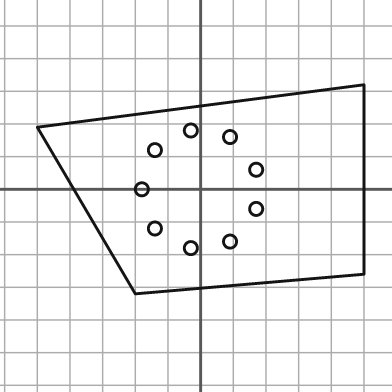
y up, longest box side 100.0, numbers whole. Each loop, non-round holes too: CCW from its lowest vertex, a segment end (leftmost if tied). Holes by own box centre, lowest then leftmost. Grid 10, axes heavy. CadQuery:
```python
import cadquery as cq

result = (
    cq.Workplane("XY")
    .moveTo(-20.0, -32.0)
    .lineTo(50.0, -26.0)
    .lineTo(50.0, 32.0)
    .lineTo(-50.0, 19.0)
    .close()
    .moveTo(-3.0, -18.0)
    .circle(2.0)
    .moveTo(9.0, -16.0)
    .circle(2.0)
    .moveTo(-14.0, -12.0)
    .circle(2.0)
    .moveTo(17.0, -6.0)
    .circle(2.0)
    .moveTo(-18.0, 0.0)
    .circle(2.0)
    .moveTo(17.0, 6.0)
    .circle(2.0)
    .moveTo(-14.0, 12.0)
    .circle(2.0)
    .moveTo(9.0, 16.0)
    .circle(2.0)
    .moveTo(-3.0, 18.0)
    .circle(2.0)
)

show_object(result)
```